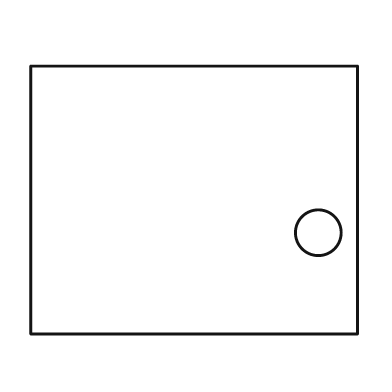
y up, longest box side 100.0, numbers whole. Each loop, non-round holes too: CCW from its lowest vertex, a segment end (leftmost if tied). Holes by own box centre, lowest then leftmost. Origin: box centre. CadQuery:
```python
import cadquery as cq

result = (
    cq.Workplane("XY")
    .moveTo(-50.0, -41.0)
    .lineTo(50.0, -41.0)
    .lineTo(50.0, 41.0)
    .lineTo(-50.0, 41.0)
    .close()
    .moveTo(38.0, -10.0)
    .circle(7.0)
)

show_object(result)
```